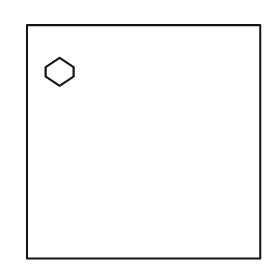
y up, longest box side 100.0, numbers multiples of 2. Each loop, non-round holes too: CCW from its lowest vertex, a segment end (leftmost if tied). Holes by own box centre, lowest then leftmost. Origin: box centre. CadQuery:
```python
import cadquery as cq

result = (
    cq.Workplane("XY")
    .moveTo(-50.0, -50.0)
    .lineTo(50.0, -50.0)
    .lineTo(50.0, 50.0)
    .lineTo(-50.0, 50.0)
    .close()
    .moveTo(-36.0, 24.0)
    .lineTo(-30.0, 28.0)
    .lineTo(-30.0, 32.0)
    .lineTo(-36.0, 36.0)
    .lineTo(-42.0, 32.0)
    .lineTo(-42.0, 28.0)
    .close()
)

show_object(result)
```